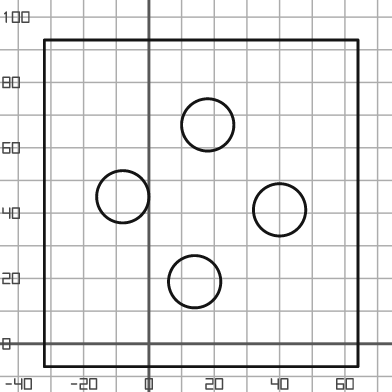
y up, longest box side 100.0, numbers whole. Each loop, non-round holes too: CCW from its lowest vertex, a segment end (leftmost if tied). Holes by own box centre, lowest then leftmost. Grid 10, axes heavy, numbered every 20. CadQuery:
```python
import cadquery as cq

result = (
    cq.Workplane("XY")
    .moveTo(-32.0, -7.0)
    .lineTo(64.0, -7.0)
    .lineTo(64.0, 93.0)
    .lineTo(-32.0, 93.0)
    .close()
    .moveTo(14.0, 19.0)
    .circle(8.0)
    .moveTo(40.0, 41.0)
    .circle(8.0)
    .moveTo(-8.0, 45.0)
    .circle(8.0)
    .moveTo(18.0, 67.0)
    .circle(8.0)
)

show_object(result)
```